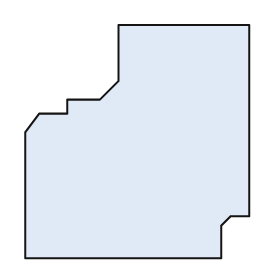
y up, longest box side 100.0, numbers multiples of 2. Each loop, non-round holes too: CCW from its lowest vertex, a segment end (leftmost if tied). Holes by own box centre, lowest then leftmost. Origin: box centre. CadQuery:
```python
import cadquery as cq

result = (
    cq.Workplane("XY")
    .moveTo(-48.0, -50.0)
    .lineTo(36.0, -50.0)
    .lineTo(36.0, -36.0)
    .lineTo(40.0, -32.0)
    .lineTo(48.0, -32.0)
    .lineTo(48.0, 50.0)
    .lineTo(-8.0, 50.0)
    .lineTo(-8.0, 26.0)
    .lineTo(-16.0, 18.0)
    .lineTo(-30.0, 18.0)
    .lineTo(-30.0, 12.0)
    .lineTo(-42.0, 12.0)
    .lineTo(-48.0, 4.0)
    .close()
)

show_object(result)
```